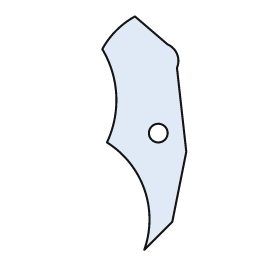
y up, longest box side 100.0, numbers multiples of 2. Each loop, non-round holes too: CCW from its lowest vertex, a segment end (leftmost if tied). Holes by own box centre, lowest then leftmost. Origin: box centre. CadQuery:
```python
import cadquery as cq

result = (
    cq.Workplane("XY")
    .moveTo(0.0, -50.0)
    .lineTo(12.0, -38.0)
    .lineTo(18.0, -8.0)
    .lineTo(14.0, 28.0)
    .threePointArc((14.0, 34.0), (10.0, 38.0))
    .lineTo(-4.0, 50.0)
    .threePointArc((-12.0, 44.0), (-18.0, 36.0))
    .threePointArc((-12.0, 16.0), (-16.0, -4.0))
    .threePointArc((0.0, -24.0), (0.0, -50.0))
    .close()
    .moveTo(6.0, 0.0)
    .circle(4.0)
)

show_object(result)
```